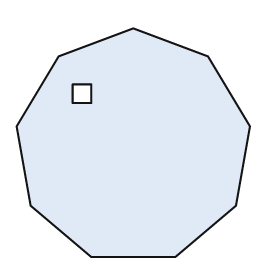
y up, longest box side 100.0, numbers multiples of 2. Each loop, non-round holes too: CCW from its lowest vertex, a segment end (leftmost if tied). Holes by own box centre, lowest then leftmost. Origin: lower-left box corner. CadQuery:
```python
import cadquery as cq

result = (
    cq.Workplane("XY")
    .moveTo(32.0, 0.0)
    .lineTo(68.0, 0.0)
    .lineTo(94.0, 22.0)
    .lineTo(100.0, 56.0)
    .lineTo(82.0, 86.0)
    .lineTo(50.0, 98.0)
    .lineTo(18.0, 86.0)
    .lineTo(0.0, 56.0)
    .lineTo(6.0, 22.0)
    .close()
    .moveTo(24.0, 66.0)
    .lineTo(32.0, 66.0)
    .lineTo(32.0, 74.0)
    .lineTo(24.0, 74.0)
    .close()
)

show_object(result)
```